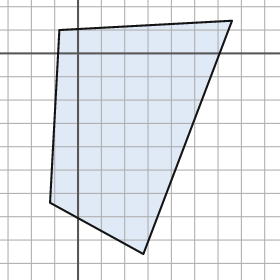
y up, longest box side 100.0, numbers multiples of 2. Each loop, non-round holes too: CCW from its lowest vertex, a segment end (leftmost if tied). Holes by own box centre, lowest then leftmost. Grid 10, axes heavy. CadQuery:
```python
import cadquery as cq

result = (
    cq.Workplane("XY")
    .moveTo(28.0, -86.0)
    .lineTo(66.0, 14.0)
    .lineTo(-8.0, 10.0)
    .lineTo(-12.0, -64.0)
    .close()
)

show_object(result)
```